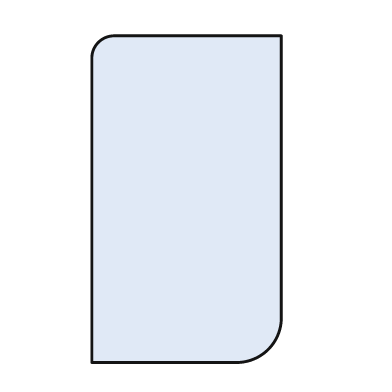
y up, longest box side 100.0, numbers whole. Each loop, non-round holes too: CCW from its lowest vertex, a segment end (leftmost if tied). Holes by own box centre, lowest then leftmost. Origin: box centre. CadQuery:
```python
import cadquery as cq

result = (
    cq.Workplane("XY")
    .moveTo(-29.0, -50.0)
    .lineTo(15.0, -50.0)
    .threePointArc((25.0, -46.0), (29.0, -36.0))
    .lineTo(29.0, 50.0)
    .lineTo(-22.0, 50.0)
    .threePointArc((-27.0, 48.0), (-29.0, 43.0))
    .close()
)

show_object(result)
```